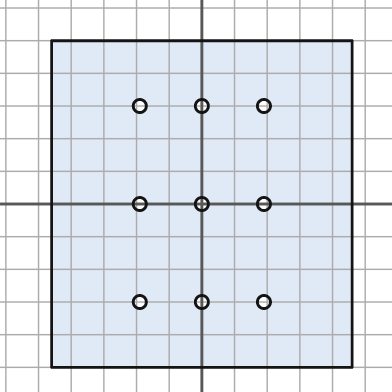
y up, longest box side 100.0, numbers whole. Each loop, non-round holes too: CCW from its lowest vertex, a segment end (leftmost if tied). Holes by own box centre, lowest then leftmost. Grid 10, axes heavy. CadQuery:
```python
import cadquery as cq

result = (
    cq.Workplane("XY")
    .moveTo(-46.0, -50.0)
    .lineTo(46.0, -50.0)
    .lineTo(46.0, 50.0)
    .lineTo(-46.0, 50.0)
    .close()
    .moveTo(-19.0, -30.0)
    .circle(2.0)
    .moveTo(0.0, -30.0)
    .circle(2.0)
    .moveTo(19.0, -30.0)
    .circle(2.0)
    .moveTo(-19.0, 0.0)
    .circle(2.0)
    .moveTo(0.0, 0.0)
    .circle(2.0)
    .moveTo(19.0, 0.0)
    .circle(2.0)
    .moveTo(-19.0, 30.0)
    .circle(2.0)
    .moveTo(0.0, 30.0)
    .circle(2.0)
    .moveTo(19.0, 30.0)
    .circle(2.0)
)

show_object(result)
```